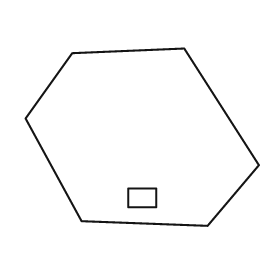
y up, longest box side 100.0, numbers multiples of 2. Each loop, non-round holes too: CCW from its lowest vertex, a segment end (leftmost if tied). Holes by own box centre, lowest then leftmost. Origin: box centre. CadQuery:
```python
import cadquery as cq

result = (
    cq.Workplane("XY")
    .moveTo(28.0, -38.0)
    .lineTo(50.0, -12.0)
    .lineTo(18.0, 38.0)
    .lineTo(-30.0, 36.0)
    .lineTo(-50.0, 8.0)
    .lineTo(-26.0, -36.0)
    .close()
    .moveTo(-6.0, -30.0)
    .lineTo(6.0, -30.0)
    .lineTo(6.0, -22.0)
    .lineTo(-6.0, -22.0)
    .close()
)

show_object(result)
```